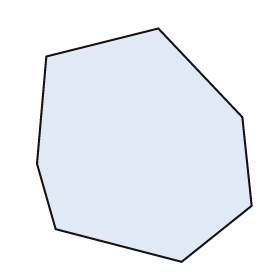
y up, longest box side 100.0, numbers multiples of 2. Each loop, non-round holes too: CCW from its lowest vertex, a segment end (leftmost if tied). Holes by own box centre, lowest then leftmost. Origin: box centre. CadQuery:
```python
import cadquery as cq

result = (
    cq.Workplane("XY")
    .moveTo(16.0, -50.0)
    .lineTo(46.0, -26.0)
    .lineTo(42.0, 12.0)
    .lineTo(6.0, 50.0)
    .lineTo(-42.0, 38.0)
    .lineTo(-46.0, -8.0)
    .lineTo(-38.0, -36.0)
    .close()
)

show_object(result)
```